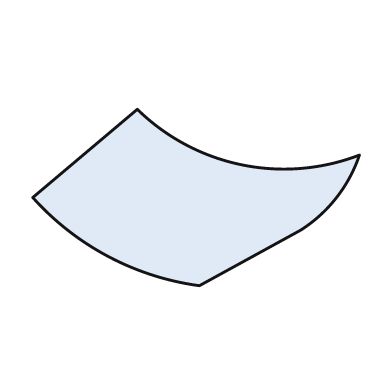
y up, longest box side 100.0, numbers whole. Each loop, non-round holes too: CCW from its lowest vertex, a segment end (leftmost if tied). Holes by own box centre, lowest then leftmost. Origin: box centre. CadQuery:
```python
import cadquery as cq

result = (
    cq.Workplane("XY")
    .moveTo(1.0, -27.0)
    .lineTo(32.0, -10.0)
    .threePointArc((43.0, 0.0), (50.0, 13.0))
    .threePointArc((14.0, 10.0), (-18.0, 27.0))
    .lineTo(-50.0, 0.0)
    .threePointArc((-27.0, -18.0), (1.0, -27.0))
    .close()
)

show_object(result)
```